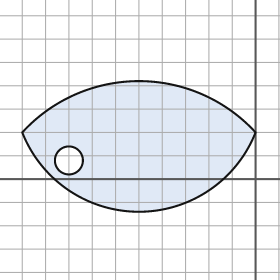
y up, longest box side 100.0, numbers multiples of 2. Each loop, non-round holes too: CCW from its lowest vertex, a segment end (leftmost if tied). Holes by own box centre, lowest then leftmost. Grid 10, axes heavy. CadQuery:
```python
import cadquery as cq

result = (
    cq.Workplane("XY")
    .moveTo(-100.0, 20.0)
    .threePointArc((-50.0, -14.0), (0.0, 20.0))
    .threePointArc((-50.0, 42.0), (-100.0, 20.0))
    .close()
    .moveTo(-80.0, 8.0)
    .circle(6.0)
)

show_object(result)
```